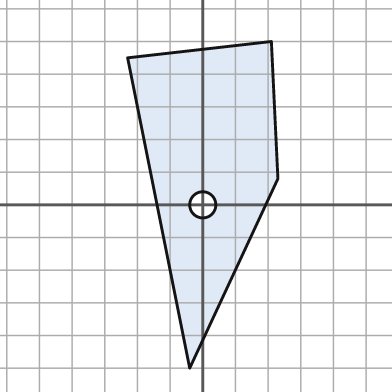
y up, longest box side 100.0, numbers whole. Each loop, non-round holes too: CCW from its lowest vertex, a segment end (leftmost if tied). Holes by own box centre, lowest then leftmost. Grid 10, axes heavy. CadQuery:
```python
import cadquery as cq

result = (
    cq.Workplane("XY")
    .moveTo(-4.0, -50.0)
    .lineTo(23.0, 8.0)
    .lineTo(21.0, 50.0)
    .lineTo(-23.0, 45.0)
    .close()
    .moveTo(0.0, 0.0)
    .circle(4.0)
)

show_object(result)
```